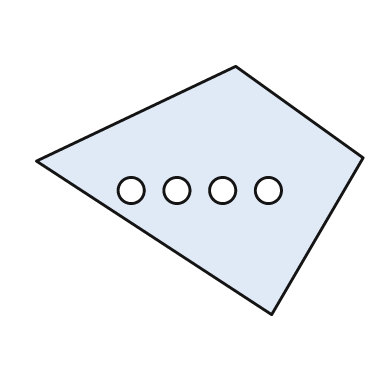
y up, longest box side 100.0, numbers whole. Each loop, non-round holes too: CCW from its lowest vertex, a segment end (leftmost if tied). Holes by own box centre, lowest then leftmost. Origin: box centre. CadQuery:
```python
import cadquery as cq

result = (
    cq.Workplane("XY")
    .moveTo(22.0, -38.0)
    .lineTo(50.0, 10.0)
    .lineTo(11.0, 38.0)
    .lineTo(-50.0, 9.0)
    .close()
    .moveTo(-21.0, 0.0)
    .circle(4.0)
    .moveTo(-7.0, 0.0)
    .circle(4.0)
    .moveTo(7.0, 0.0)
    .circle(4.0)
    .moveTo(21.0, 0.0)
    .circle(4.0)
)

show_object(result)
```